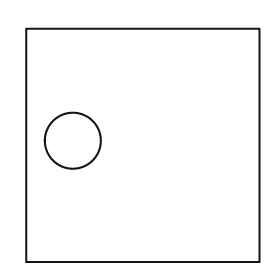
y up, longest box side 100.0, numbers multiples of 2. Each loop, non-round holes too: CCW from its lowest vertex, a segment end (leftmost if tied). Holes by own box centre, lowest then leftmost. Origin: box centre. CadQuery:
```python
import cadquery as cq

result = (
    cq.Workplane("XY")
    .moveTo(-50.0, -50.0)
    .lineTo(50.0, -50.0)
    .lineTo(50.0, 50.0)
    .lineTo(-50.0, 50.0)
    .close()
    .moveTo(-30.0, 2.0)
    .circle(12.0)
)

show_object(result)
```